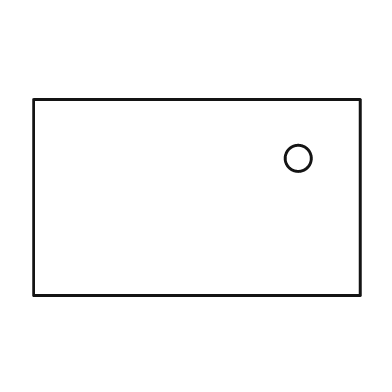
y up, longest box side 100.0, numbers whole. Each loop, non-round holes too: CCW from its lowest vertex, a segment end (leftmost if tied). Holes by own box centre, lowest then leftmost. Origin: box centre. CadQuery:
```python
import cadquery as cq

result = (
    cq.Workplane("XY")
    .moveTo(-50.0, -30.0)
    .lineTo(50.0, -30.0)
    .lineTo(50.0, 30.0)
    .lineTo(-50.0, 30.0)
    .close()
    .moveTo(31.0, 12.0)
    .circle(4.0)
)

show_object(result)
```